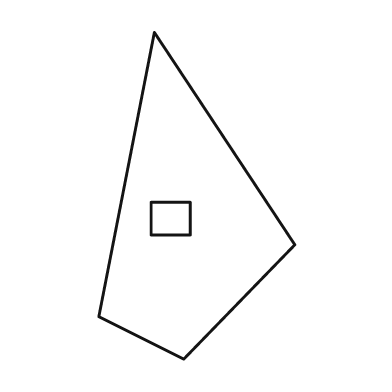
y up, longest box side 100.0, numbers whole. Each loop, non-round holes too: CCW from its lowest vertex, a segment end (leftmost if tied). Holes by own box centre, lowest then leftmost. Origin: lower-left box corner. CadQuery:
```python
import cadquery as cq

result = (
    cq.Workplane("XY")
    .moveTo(26.0, 0.0)
    .lineTo(60.0, 35.0)
    .lineTo(17.0, 100.0)
    .lineTo(0.0, 13.0)
    .close()
    .moveTo(16.0, 38.0)
    .lineTo(28.0, 38.0)
    .lineTo(28.0, 48.0)
    .lineTo(16.0, 48.0)
    .close()
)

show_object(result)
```